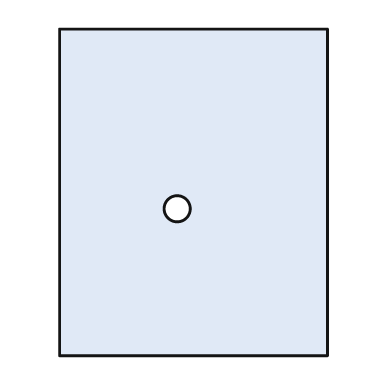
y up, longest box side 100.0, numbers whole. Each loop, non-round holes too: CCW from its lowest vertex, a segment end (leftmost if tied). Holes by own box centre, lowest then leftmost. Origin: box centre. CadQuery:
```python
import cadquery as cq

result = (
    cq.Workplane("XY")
    .moveTo(-41.0, -50.0)
    .lineTo(41.0, -50.0)
    .lineTo(41.0, 50.0)
    .lineTo(-41.0, 50.0)
    .close()
    .moveTo(-5.0, -5.0)
    .circle(4.0)
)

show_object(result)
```